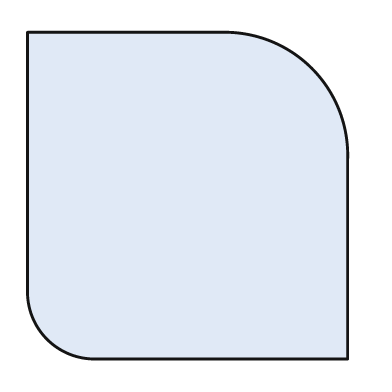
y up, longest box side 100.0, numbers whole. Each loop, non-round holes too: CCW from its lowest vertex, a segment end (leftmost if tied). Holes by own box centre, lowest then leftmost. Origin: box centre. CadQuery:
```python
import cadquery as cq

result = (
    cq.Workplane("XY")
    .moveTo(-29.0, -50.0)
    .lineTo(49.0, -50.0)
    .lineTo(49.0, 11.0)
    .threePointArc((38.0, 39.0), (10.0, 50.0))
    .lineTo(-49.0, 50.0)
    .lineTo(-49.0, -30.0)
    .threePointArc((-43.0, -44.0), (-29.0, -50.0))
    .close()
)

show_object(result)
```